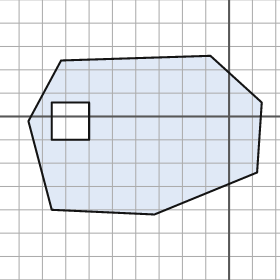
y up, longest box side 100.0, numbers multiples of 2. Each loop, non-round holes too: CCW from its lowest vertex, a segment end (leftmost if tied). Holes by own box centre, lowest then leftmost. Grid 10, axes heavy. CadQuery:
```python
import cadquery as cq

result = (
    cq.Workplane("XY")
    .moveTo(-32.0, -42.0)
    .lineTo(12.0, -24.0)
    .lineTo(14.0, 6.0)
    .lineTo(-8.0, 26.0)
    .lineTo(-72.0, 24.0)
    .lineTo(-86.0, -2.0)
    .lineTo(-76.0, -40.0)
    .close()
    .moveTo(-76.0, -10.0)
    .lineTo(-60.0, -10.0)
    .lineTo(-60.0, 6.0)
    .lineTo(-76.0, 6.0)
    .close()
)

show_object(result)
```